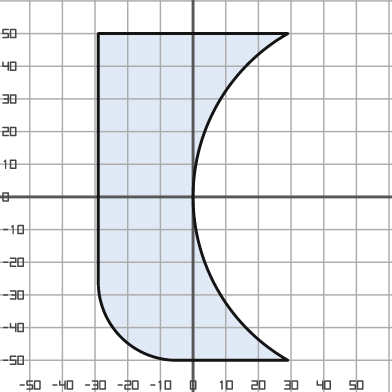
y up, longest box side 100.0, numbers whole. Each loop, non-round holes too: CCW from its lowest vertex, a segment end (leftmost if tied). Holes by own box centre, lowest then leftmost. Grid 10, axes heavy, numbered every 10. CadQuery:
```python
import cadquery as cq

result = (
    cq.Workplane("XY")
    .moveTo(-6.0, -50.0)
    .lineTo(29.0, -50.0)
    .threePointArc((0.0, 0.0), (29.0, 50.0))
    .lineTo(-29.0, 50.0)
    .lineTo(-29.0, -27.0)
    .threePointArc((-22.0, -43.0), (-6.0, -50.0))
    .close()
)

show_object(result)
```